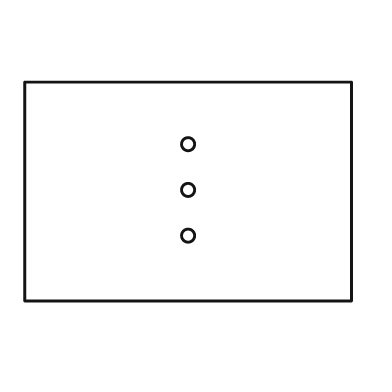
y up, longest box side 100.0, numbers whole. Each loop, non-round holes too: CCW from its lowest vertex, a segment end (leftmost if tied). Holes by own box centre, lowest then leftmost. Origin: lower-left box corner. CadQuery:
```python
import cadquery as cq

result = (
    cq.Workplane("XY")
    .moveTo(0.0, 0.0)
    .lineTo(100.0, 0.0)
    .lineTo(100.0, 67.0)
    .lineTo(0.0, 67.0)
    .close()
    .moveTo(50.0, 20.0)
    .circle(2.0)
    .moveTo(50.0, 34.0)
    .circle(2.0)
    .moveTo(50.0, 48.0)
    .circle(2.0)
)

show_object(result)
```